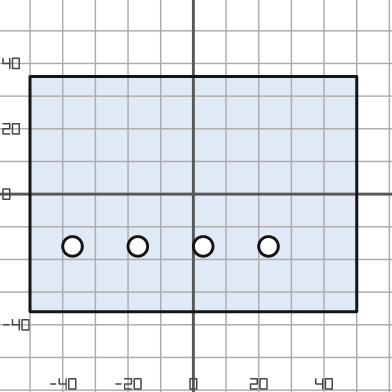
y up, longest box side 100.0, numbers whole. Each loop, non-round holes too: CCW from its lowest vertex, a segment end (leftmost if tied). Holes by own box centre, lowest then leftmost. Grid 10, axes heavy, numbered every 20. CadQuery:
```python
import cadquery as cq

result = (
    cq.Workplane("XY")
    .moveTo(-50.0, -36.0)
    .lineTo(50.0, -36.0)
    .lineTo(50.0, 36.0)
    .lineTo(-50.0, 36.0)
    .close()
    .moveTo(-37.0, -16.0)
    .circle(3.0)
    .moveTo(-17.0, -16.0)
    .circle(3.0)
    .moveTo(3.0, -16.0)
    .circle(3.0)
    .moveTo(23.0, -16.0)
    .circle(3.0)
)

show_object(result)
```